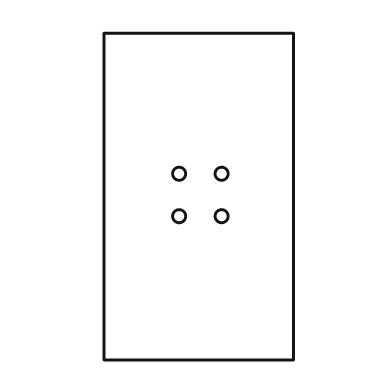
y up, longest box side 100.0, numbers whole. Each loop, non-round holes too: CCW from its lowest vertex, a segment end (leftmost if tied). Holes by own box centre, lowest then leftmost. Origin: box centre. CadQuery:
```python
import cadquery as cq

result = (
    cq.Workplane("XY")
    .moveTo(-29.0, -50.0)
    .lineTo(29.0, -50.0)
    .lineTo(29.0, 50.0)
    .lineTo(-29.0, 50.0)
    .close()
    .moveTo(-6.0, -6.0)
    .circle(2.0)
    .moveTo(7.0, -6.0)
    .circle(2.0)
    .moveTo(-6.0, 7.0)
    .circle(2.0)
    .moveTo(7.0, 7.0)
    .circle(2.0)
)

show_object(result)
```